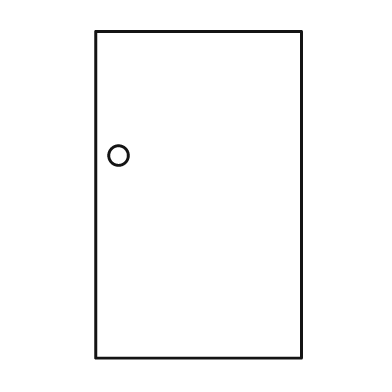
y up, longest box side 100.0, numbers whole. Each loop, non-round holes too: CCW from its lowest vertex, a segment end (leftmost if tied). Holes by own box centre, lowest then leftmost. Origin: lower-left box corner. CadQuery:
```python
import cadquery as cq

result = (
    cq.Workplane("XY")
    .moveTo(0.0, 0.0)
    .lineTo(63.0, 0.0)
    .lineTo(63.0, 100.0)
    .lineTo(0.0, 100.0)
    .close()
    .moveTo(7.0, 62.0)
    .circle(3.0)
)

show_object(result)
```